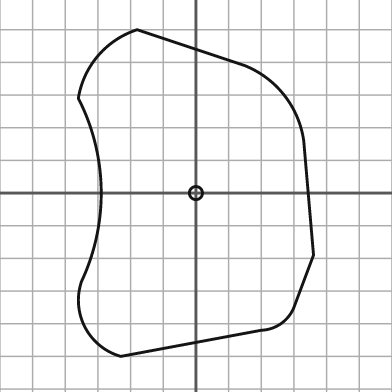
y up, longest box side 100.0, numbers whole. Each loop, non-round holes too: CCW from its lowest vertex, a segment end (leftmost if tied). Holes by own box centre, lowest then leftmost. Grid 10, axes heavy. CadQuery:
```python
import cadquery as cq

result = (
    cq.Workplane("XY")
    .moveTo(-23.0, -50.0)
    .lineTo(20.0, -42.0)
    .threePointArc((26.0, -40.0), (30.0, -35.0))
    .lineTo(36.0, -19.0)
    .lineTo(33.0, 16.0)
    .threePointArc((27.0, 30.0), (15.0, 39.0))
    .lineTo(-18.0, 50.0)
    .threePointArc((-30.0, 42.0), (-36.0, 29.0))
    .threePointArc((-29.0, 1.0), (-35.0, -27.0))
    .threePointArc((-34.0, -41.0), (-23.0, -50.0))
    .close()
    .moveTo(0.0, 0.0)
    .circle(2.0)
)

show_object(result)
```